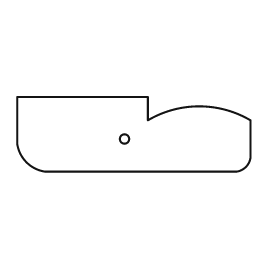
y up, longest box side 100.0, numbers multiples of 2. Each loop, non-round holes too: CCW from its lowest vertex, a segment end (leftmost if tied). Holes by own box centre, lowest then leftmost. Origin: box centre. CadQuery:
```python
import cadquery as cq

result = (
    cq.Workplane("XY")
    .moveTo(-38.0, -16.0)
    .lineTo(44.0, -16.0)
    .threePointArc((48.0, -14.0), (50.0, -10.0))
    .lineTo(50.0, 6.0)
    .threePointArc((28.0, 12.0), (6.0, 6.0))
    .lineTo(6.0, 16.0)
    .lineTo(-50.0, 16.0)
    .lineTo(-50.0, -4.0)
    .threePointArc((-46.0, -12.0), (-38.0, -16.0))
    .close()
    .moveTo(-4.0, -2.0)
    .circle(2.0)
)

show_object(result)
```